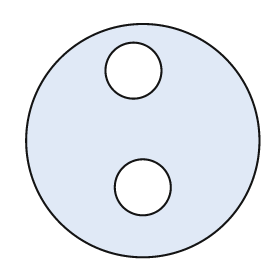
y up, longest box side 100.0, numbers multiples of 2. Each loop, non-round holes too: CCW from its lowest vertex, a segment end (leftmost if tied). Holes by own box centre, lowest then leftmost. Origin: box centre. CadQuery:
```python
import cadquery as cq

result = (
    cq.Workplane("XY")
    .moveTo(0.0, 0.0)
    .circle(50.0)
    .moveTo(0.0, -20.0)
    .circle(12.0)
    .moveTo(-4.0, 30.0)
    .circle(12.0)
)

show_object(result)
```